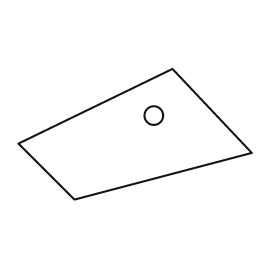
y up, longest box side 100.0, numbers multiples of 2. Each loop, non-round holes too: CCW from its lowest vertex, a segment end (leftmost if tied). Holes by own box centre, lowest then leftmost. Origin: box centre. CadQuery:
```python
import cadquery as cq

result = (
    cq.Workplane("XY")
    .moveTo(-26.0, -28.0)
    .lineTo(50.0, -8.0)
    .lineTo(16.0, 28.0)
    .lineTo(-50.0, -4.0)
    .close()
    .moveTo(8.0, 8.0)
    .circle(4.0)
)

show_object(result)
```